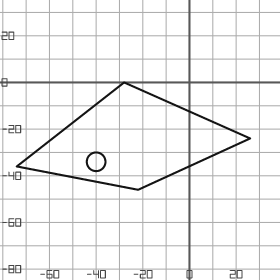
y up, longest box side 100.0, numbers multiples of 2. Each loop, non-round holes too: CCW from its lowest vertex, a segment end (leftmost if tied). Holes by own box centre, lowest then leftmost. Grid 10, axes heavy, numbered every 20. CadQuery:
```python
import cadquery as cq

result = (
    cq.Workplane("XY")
    .moveTo(-22.0, -46.0)
    .lineTo(26.0, -24.0)
    .lineTo(-28.0, 0.0)
    .lineTo(-74.0, -36.0)
    .close()
    .moveTo(-40.0, -34.0)
    .circle(4.0)
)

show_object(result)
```